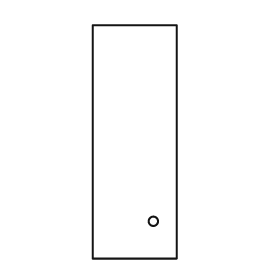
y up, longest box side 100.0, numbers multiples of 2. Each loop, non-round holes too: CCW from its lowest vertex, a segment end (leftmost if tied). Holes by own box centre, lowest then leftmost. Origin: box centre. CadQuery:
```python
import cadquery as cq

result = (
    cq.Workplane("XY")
    .moveTo(-18.0, -50.0)
    .lineTo(18.0, -50.0)
    .lineTo(18.0, 50.0)
    .lineTo(-18.0, 50.0)
    .close()
    .moveTo(8.0, -34.0)
    .circle(2.0)
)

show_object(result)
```